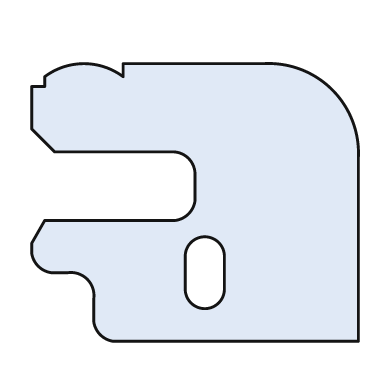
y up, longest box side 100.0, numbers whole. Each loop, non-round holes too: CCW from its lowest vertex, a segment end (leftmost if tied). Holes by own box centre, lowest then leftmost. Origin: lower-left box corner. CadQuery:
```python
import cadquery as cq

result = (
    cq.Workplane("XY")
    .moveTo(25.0, 0.0)
    .lineTo(100.0, 0.0)
    .lineTo(100.0, 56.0)
    .threePointArc((92.0, 77.0), (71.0, 85.0))
    .lineTo(28.0, 85.0)
    .lineTo(28.0, 81.0)
    .threePointArc((16.0, 85.0), (4.0, 81.0))
    .lineTo(4.0, 78.0)
    .lineTo(0.0, 78.0)
    .lineTo(0.0, 65.0)
    .lineTo(7.0, 58.0)
    .lineTo(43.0, 58.0)
    .threePointArc((48.0, 56.0), (50.0, 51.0))
    .lineTo(50.0, 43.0)
    .threePointArc((48.0, 39.0), (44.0, 37.0))
    .lineTo(4.0, 37.0)
    .lineTo(0.0, 30.0)
    .lineTo(0.0, 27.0)
    .threePointArc((2.0, 23.0), (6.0, 21.0))
    .lineTo(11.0, 21.0)
    .threePointArc((17.0, 19.0), (19.0, 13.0))
    .lineTo(19.0, 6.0)
    .threePointArc((21.0, 2.0), (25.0, 0.0))
    .close()
    .moveTo(47.0, 16.0)
    .threePointArc((53.0, 10.0), (59.0, 16.0))
    .lineTo(59.0, 26.0)
    .threePointArc((53.0, 32.0), (47.0, 26.0))
    .close()
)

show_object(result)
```